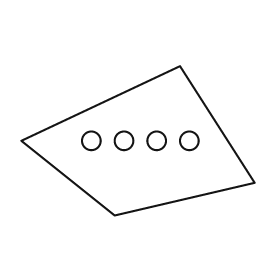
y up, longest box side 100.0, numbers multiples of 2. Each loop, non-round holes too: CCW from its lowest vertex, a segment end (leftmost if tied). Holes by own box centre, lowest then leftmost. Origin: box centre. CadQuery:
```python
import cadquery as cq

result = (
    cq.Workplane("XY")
    .moveTo(-10.0, -32.0)
    .lineTo(50.0, -18.0)
    .lineTo(18.0, 32.0)
    .lineTo(-50.0, 0.0)
    .close()
    .moveTo(-20.0, 0.0)
    .circle(4.0)
    .moveTo(-6.0, 0.0)
    .circle(4.0)
    .moveTo(8.0, 0.0)
    .circle(4.0)
    .moveTo(22.0, 0.0)
    .circle(4.0)
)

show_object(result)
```